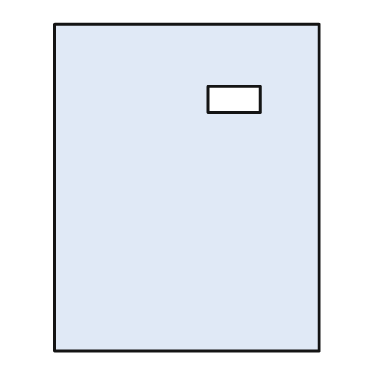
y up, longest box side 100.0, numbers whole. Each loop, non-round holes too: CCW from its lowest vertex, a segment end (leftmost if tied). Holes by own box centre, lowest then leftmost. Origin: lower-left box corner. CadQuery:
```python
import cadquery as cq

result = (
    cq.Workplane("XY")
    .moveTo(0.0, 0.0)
    .lineTo(81.0, 0.0)
    .lineTo(81.0, 100.0)
    .lineTo(0.0, 100.0)
    .close()
    .moveTo(47.0, 73.0)
    .lineTo(63.0, 73.0)
    .lineTo(63.0, 81.0)
    .lineTo(47.0, 81.0)
    .close()
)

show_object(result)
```